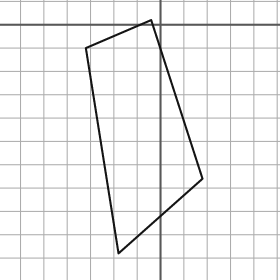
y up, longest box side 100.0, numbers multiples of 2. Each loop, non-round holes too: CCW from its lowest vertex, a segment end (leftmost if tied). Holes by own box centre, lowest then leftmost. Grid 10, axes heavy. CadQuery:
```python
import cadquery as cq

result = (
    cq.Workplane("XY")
    .moveTo(-18.0, -98.0)
    .lineTo(18.0, -66.0)
    .lineTo(-4.0, 2.0)
    .lineTo(-32.0, -10.0)
    .close()
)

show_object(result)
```